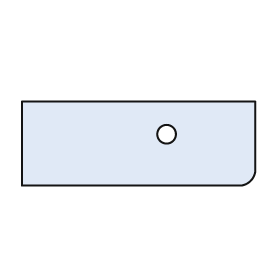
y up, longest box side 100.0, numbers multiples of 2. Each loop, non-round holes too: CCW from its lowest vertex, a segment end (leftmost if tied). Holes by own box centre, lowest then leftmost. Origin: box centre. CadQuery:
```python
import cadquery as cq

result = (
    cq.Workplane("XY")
    .moveTo(-50.0, -18.0)
    .lineTo(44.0, -18.0)
    .threePointArc((48.0, -16.0), (50.0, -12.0))
    .lineTo(50.0, 18.0)
    .lineTo(-50.0, 18.0)
    .close()
    .moveTo(12.0, 4.0)
    .circle(4.0)
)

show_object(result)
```